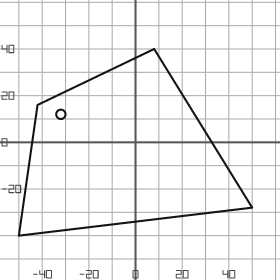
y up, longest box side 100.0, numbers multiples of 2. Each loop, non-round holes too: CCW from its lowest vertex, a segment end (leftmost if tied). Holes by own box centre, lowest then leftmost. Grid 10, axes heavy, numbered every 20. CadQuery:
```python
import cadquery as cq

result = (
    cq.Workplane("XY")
    .moveTo(-50.0, -40.0)
    .lineTo(50.0, -28.0)
    .lineTo(8.0, 40.0)
    .lineTo(-42.0, 16.0)
    .close()
    .moveTo(-32.0, 12.0)
    .circle(2.0)
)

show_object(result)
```